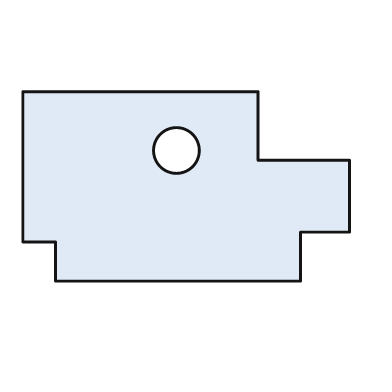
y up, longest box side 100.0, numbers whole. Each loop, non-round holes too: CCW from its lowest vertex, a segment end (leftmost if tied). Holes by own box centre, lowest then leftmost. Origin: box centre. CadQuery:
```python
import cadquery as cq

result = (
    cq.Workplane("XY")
    .moveTo(-40.0, -29.0)
    .lineTo(35.0, -29.0)
    .lineTo(35.0, -14.0)
    .lineTo(50.0, -14.0)
    .lineTo(50.0, 8.0)
    .lineTo(22.0, 8.0)
    .lineTo(22.0, 29.0)
    .lineTo(-50.0, 29.0)
    .lineTo(-50.0, -17.0)
    .lineTo(-40.0, -17.0)
    .close()
    .moveTo(-3.0, 11.0)
    .circle(7.0)
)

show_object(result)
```